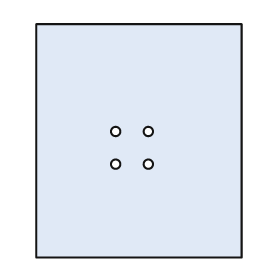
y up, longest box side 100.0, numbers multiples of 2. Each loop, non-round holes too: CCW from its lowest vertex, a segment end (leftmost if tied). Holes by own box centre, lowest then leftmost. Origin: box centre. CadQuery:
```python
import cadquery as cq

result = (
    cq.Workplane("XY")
    .moveTo(-44.0, -50.0)
    .lineTo(44.0, -50.0)
    .lineTo(44.0, 50.0)
    .lineTo(-44.0, 50.0)
    .close()
    .moveTo(-10.0, -10.0)
    .circle(2.0)
    .moveTo(4.0, -10.0)
    .circle(2.0)
    .moveTo(-10.0, 4.0)
    .circle(2.0)
    .moveTo(4.0, 4.0)
    .circle(2.0)
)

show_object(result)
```